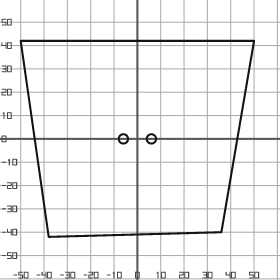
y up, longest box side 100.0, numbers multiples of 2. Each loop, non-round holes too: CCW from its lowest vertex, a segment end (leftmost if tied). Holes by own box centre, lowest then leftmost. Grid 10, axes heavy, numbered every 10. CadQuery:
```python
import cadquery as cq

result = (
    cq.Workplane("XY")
    .moveTo(-38.0, -42.0)
    .lineTo(36.0, -40.0)
    .lineTo(50.0, 42.0)
    .lineTo(-50.0, 42.0)
    .close()
    .moveTo(-6.0, 0.0)
    .circle(2.0)
    .moveTo(6.0, 0.0)
    .circle(2.0)
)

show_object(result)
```